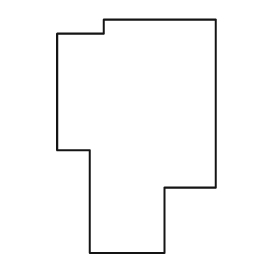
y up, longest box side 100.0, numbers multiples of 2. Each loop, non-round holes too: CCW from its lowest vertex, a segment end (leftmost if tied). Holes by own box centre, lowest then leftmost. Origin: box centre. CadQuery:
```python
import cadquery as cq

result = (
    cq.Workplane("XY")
    .moveTo(-20.0, -50.0)
    .lineTo(12.0, -50.0)
    .lineTo(12.0, -22.0)
    .lineTo(34.0, -22.0)
    .lineTo(34.0, 50.0)
    .lineTo(-14.0, 50.0)
    .lineTo(-14.0, 44.0)
    .lineTo(-34.0, 44.0)
    .lineTo(-34.0, -6.0)
    .lineTo(-20.0, -6.0)
    .close()
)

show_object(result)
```